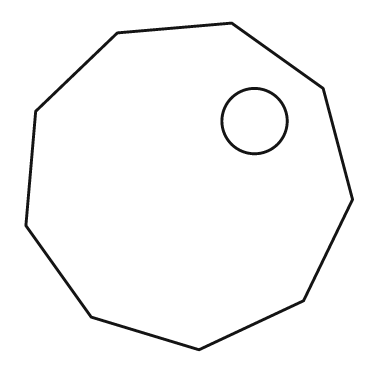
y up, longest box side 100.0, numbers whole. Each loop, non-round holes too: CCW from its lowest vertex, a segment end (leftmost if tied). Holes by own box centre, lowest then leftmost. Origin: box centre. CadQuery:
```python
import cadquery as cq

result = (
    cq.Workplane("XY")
    .moveTo(3.0, -50.0)
    .lineTo(35.0, -35.0)
    .lineTo(50.0, -4.0)
    .lineTo(41.0, 30.0)
    .lineTo(13.0, 50.0)
    .lineTo(-22.0, 47.0)
    .lineTo(-47.0, 23.0)
    .lineTo(-50.0, -12.0)
    .lineTo(-30.0, -40.0)
    .close()
    .moveTo(20.0, 20.0)
    .circle(10.0)
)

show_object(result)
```